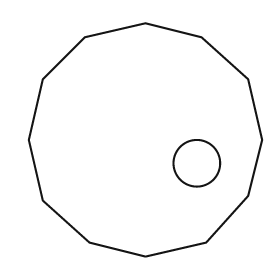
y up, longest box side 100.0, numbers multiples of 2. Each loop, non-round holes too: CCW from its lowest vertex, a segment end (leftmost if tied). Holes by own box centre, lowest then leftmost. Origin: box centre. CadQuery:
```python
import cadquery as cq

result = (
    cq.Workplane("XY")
    .moveTo(0.0, -50.0)
    .lineTo(26.0, -44.0)
    .lineTo(44.0, -24.0)
    .lineTo(50.0, 0.0)
    .lineTo(44.0, 26.0)
    .lineTo(24.0, 44.0)
    .lineTo(0.0, 50.0)
    .lineTo(-26.0, 44.0)
    .lineTo(-44.0, 26.0)
    .lineTo(-50.0, 0.0)
    .lineTo(-44.0, -26.0)
    .lineTo(-24.0, -44.0)
    .close()
    .moveTo(22.0, -10.0)
    .circle(10.0)
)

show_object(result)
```